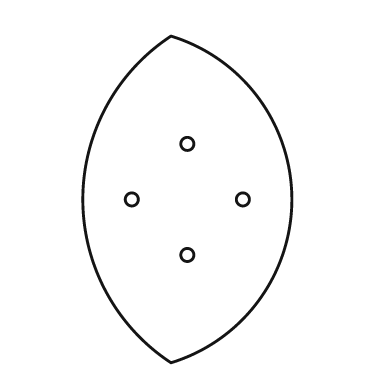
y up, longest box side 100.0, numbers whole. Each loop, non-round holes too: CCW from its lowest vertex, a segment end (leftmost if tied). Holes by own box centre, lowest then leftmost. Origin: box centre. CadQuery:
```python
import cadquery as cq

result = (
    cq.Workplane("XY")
    .moveTo(-5.0, -50.0)
    .threePointArc((32.0, 0.0), (-5.0, 50.0))
    .threePointArc((-32.0, 0.0), (-5.0, -50.0))
    .close()
    .moveTo(0.0, -17.0)
    .circle(2.0)
    .moveTo(-17.0, 0.0)
    .circle(2.0)
    .moveTo(17.0, 0.0)
    .circle(2.0)
    .moveTo(0.0, 17.0)
    .circle(2.0)
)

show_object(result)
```